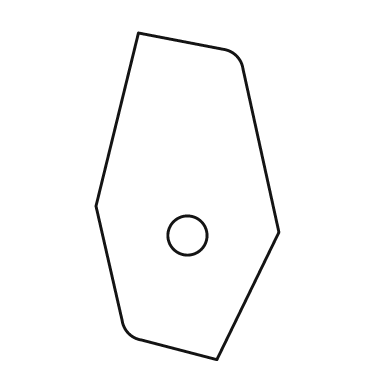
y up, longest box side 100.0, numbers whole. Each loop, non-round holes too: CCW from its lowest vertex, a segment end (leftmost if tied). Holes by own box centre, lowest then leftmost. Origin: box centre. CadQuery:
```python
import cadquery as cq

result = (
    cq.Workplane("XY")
    .moveTo(9.0, -50.0)
    .lineTo(28.0, -11.0)
    .lineTo(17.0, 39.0)
    .threePointArc((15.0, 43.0), (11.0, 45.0))
    .lineTo(-15.0, 50.0)
    .lineTo(-28.0, -3.0)
    .lineTo(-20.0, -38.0)
    .threePointArc((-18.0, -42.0), (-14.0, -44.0))
    .close()
    .moveTo(0.0, -12.0)
    .circle(6.0)
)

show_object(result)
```